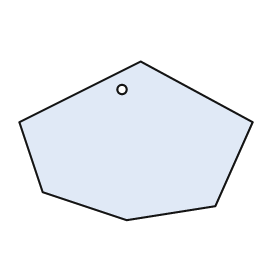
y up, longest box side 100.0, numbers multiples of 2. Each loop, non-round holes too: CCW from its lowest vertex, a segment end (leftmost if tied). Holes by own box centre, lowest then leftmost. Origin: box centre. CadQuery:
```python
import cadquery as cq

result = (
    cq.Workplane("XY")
    .moveTo(-4.0, -34.0)
    .lineTo(34.0, -28.0)
    .lineTo(50.0, 8.0)
    .lineTo(2.0, 34.0)
    .lineTo(-50.0, 8.0)
    .lineTo(-40.0, -22.0)
    .close()
    .moveTo(-6.0, 22.0)
    .circle(2.0)
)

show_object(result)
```